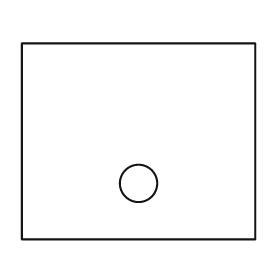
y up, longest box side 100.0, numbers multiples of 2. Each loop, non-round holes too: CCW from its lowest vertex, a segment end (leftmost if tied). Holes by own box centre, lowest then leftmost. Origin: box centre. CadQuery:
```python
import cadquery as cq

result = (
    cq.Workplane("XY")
    .moveTo(-50.0, -42.0)
    .lineTo(50.0, -42.0)
    .lineTo(50.0, 42.0)
    .lineTo(-50.0, 42.0)
    .close()
    .moveTo(0.0, -18.0)
    .circle(8.0)
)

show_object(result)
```